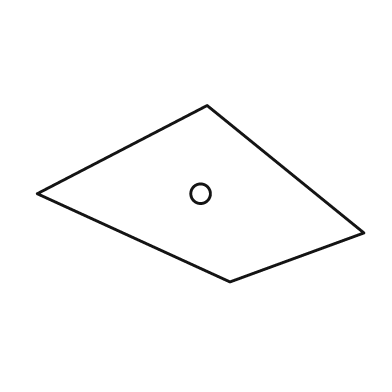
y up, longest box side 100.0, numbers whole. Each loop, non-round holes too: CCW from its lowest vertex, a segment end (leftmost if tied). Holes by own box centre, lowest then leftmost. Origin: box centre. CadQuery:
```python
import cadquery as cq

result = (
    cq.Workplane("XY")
    .moveTo(9.0, -27.0)
    .lineTo(50.0, -12.0)
    .lineTo(2.0, 27.0)
    .lineTo(-50.0, 0.0)
    .close()
    .moveTo(0.0, 0.0)
    .circle(3.0)
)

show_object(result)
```